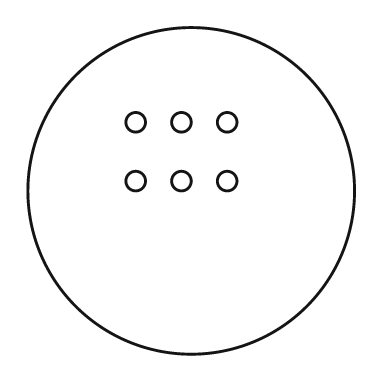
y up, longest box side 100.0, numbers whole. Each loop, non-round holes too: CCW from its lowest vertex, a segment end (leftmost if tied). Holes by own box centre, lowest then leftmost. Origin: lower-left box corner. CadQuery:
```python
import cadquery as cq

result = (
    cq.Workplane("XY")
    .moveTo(50.0, 50.0)
    .circle(50.0)
    .moveTo(33.0, 53.0)
    .circle(3.0)
    .moveTo(47.0, 53.0)
    .circle(3.0)
    .moveTo(61.0, 53.0)
    .circle(3.0)
    .moveTo(33.0, 71.0)
    .circle(3.0)
    .moveTo(47.0, 71.0)
    .circle(3.0)
    .moveTo(61.0, 71.0)
    .circle(3.0)
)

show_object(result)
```